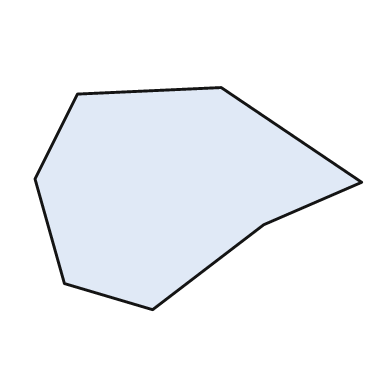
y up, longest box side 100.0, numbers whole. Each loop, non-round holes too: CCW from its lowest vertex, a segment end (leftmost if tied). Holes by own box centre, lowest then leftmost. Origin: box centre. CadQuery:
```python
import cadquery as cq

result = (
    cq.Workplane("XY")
    .moveTo(-14.0, -34.0)
    .lineTo(20.0, -8.0)
    .lineTo(50.0, 5.0)
    .lineTo(7.0, 34.0)
    .lineTo(-37.0, 32.0)
    .lineTo(-50.0, 6.0)
    .lineTo(-41.0, -26.0)
    .close()
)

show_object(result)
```